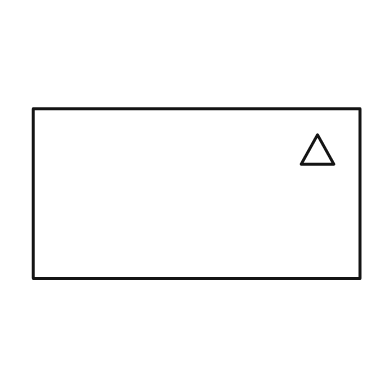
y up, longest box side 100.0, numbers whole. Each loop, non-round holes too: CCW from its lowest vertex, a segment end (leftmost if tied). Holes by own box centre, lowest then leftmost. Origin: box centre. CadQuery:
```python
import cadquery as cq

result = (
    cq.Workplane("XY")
    .moveTo(-50.0, -26.0)
    .lineTo(50.0, -26.0)
    .lineTo(50.0, 26.0)
    .lineTo(-50.0, 26.0)
    .close()
    .moveTo(32.0, 9.0)
    .lineTo(42.0, 9.0)
    .lineTo(37.0, 18.0)
    .close()
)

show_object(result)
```